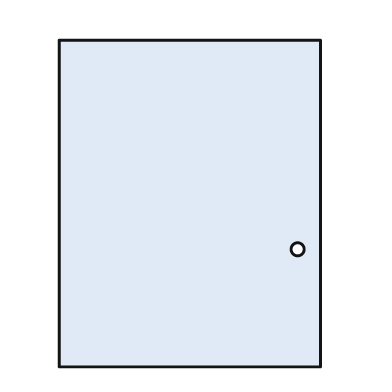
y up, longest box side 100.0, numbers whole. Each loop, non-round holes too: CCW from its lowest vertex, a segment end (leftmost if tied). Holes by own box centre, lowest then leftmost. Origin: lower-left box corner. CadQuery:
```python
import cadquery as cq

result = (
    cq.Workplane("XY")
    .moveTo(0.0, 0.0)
    .lineTo(80.0, 0.0)
    .lineTo(80.0, 100.0)
    .lineTo(0.0, 100.0)
    .close()
    .moveTo(73.0, 36.0)
    .circle(2.0)
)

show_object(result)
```